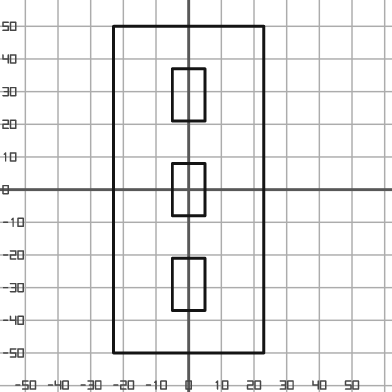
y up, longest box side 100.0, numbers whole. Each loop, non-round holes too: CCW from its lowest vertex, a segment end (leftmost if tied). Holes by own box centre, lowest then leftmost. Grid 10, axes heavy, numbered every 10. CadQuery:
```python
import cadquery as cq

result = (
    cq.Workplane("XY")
    .moveTo(-23.0, -50.0)
    .lineTo(23.0, -50.0)
    .lineTo(23.0, 50.0)
    .lineTo(-23.0, 50.0)
    .close()
    .moveTo(-5.0, -37.0)
    .lineTo(5.0, -37.0)
    .lineTo(5.0, -21.0)
    .lineTo(-5.0, -21.0)
    .close()
    .moveTo(-5.0, -8.0)
    .lineTo(5.0, -8.0)
    .lineTo(5.0, 8.0)
    .lineTo(-5.0, 8.0)
    .close()
    .moveTo(-5.0, 21.0)
    .lineTo(5.0, 21.0)
    .lineTo(5.0, 37.0)
    .lineTo(-5.0, 37.0)
    .close()
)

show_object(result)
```